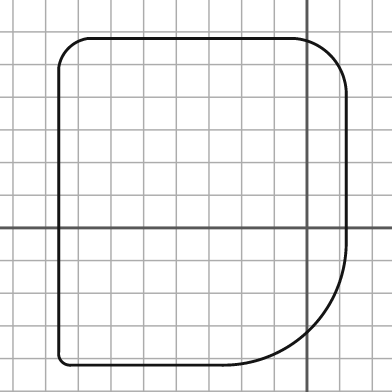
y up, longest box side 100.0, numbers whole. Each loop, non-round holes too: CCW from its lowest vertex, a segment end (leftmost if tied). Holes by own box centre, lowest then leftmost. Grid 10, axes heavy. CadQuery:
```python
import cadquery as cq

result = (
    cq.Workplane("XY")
    .moveTo(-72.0, -42.0)
    .lineTo(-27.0, -42.0)
    .threePointArc((1.0, -31.0), (12.0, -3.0))
    .lineTo(12.0, 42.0)
    .threePointArc((7.0, 53.0), (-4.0, 58.0))
    .lineTo(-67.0, 58.0)
    .threePointArc((-73.0, 55.0), (-76.0, 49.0))
    .lineTo(-76.0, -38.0)
    .threePointArc((-75.0, -41.0), (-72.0, -42.0))
    .close()
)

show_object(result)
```